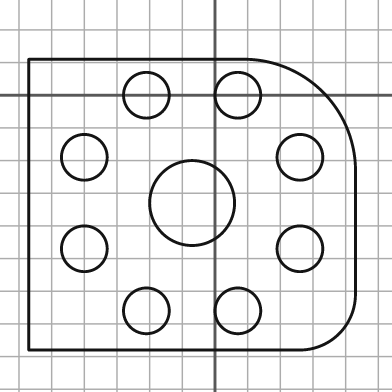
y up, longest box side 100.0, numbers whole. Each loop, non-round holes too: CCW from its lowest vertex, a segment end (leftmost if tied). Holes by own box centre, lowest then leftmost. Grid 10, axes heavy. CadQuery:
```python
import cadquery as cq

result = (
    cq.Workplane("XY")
    .moveTo(-57.0, -78.0)
    .lineTo(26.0, -78.0)
    .threePointArc((38.0, -73.0), (43.0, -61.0))
    .lineTo(43.0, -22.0)
    .threePointArc((33.0, 1.0), (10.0, 11.0))
    .lineTo(-57.0, 11.0)
    .close()
    .moveTo(-21.0, -66.0)
    .circle(7.0)
    .moveTo(7.0, -66.0)
    .circle(7.0)
    .moveTo(-40.0, -47.0)
    .circle(7.0)
    .moveTo(26.0, -47.0)
    .circle(7.0)
    .moveTo(-7.0, -33.0)
    .circle(13.0)
    .moveTo(-40.0, -19.0)
    .circle(7.0)
    .moveTo(26.0, -19.0)
    .circle(7.0)
    .moveTo(-21.0, 0.0)
    .circle(7.0)
    .moveTo(7.0, 0.0)
    .circle(7.0)
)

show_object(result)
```